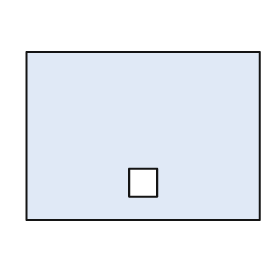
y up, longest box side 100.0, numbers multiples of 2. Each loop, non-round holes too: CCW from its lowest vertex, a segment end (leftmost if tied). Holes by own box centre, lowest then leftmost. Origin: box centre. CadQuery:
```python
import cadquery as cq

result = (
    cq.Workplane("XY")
    .moveTo(-50.0, -36.0)
    .lineTo(50.0, -36.0)
    .lineTo(50.0, 36.0)
    .lineTo(-50.0, 36.0)
    .close()
    .moveTo(-6.0, -26.0)
    .lineTo(6.0, -26.0)
    .lineTo(6.0, -14.0)
    .lineTo(-6.0, -14.0)
    .close()
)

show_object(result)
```